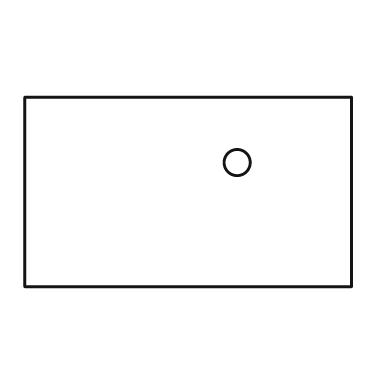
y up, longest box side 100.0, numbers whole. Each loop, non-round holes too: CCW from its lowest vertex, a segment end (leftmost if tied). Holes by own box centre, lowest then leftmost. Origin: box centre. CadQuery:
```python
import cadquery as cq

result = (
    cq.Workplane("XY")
    .moveTo(-50.0, -29.0)
    .lineTo(50.0, -29.0)
    .lineTo(50.0, 29.0)
    .lineTo(-50.0, 29.0)
    .close()
    .moveTo(15.0, 9.0)
    .circle(4.0)
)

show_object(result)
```